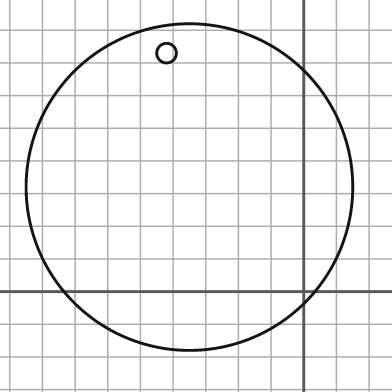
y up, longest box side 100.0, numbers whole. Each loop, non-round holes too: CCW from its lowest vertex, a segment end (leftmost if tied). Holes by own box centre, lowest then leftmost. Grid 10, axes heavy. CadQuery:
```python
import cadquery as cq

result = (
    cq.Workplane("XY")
    .moveTo(-35.0, 32.0)
    .circle(50.0)
    .moveTo(-42.0, 73.0)
    .circle(3.0)
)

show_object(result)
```